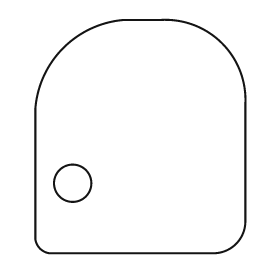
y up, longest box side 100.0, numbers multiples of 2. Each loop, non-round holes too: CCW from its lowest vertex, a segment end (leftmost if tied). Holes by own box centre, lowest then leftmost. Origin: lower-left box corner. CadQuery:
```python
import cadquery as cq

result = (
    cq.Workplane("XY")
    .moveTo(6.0, 0.0)
    .lineTo(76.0, 0.0)
    .threePointArc((86.0, 4.0), (90.0, 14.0))
    .lineTo(90.0, 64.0)
    .threePointArc((80.0, 90.0), (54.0, 100.0))
    .lineTo(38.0, 100.0)
    .threePointArc((12.0, 88.0), (0.0, 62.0))
    .lineTo(0.0, 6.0)
    .threePointArc((2.0, 2.0), (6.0, 0.0))
    .close()
    .moveTo(16.0, 30.0)
    .circle(8.0)
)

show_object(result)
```